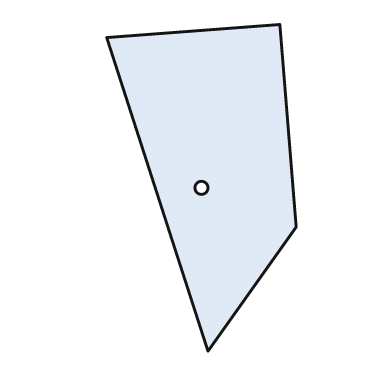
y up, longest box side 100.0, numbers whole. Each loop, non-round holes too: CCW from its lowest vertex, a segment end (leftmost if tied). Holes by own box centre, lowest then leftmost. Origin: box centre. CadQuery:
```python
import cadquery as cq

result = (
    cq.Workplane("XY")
    .moveTo(2.0, -50.0)
    .lineTo(29.0, -12.0)
    .lineTo(24.0, 50.0)
    .lineTo(-29.0, 46.0)
    .close()
    .moveTo(0.0, 0.0)
    .circle(2.0)
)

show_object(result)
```